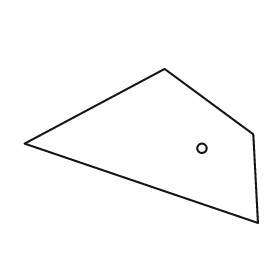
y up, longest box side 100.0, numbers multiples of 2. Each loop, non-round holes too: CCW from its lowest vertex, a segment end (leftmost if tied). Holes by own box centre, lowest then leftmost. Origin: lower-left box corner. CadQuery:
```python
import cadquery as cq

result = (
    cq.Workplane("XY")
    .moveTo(100.0, 0.0)
    .lineTo(98.0, 38.0)
    .lineTo(60.0, 66.0)
    .lineTo(0.0, 34.0)
    .close()
    .moveTo(76.0, 32.0)
    .circle(2.0)
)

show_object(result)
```